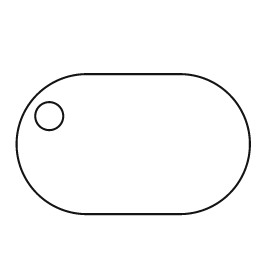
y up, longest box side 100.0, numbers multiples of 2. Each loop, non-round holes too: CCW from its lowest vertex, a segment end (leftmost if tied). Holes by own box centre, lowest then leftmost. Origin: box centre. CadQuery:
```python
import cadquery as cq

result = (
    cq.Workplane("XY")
    .moveTo(-20.0, -30.0)
    .lineTo(20.0, -30.0)
    .threePointArc((50.0, 0.0), (20.0, 30.0))
    .lineTo(-20.0, 30.0)
    .threePointArc((-50.0, 0.0), (-20.0, -30.0))
    .close()
    .moveTo(-36.0, 12.0)
    .circle(6.0)
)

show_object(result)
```